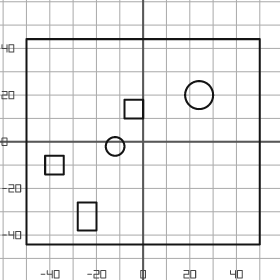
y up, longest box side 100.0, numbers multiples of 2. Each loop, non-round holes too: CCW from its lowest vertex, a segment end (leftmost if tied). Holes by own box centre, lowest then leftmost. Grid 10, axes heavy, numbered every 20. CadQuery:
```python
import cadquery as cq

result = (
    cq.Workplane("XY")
    .moveTo(-50.0, -44.0)
    .lineTo(50.0, -44.0)
    .lineTo(50.0, 44.0)
    .lineTo(-50.0, 44.0)
    .close()
    .moveTo(-28.0, -38.0)
    .lineTo(-20.0, -38.0)
    .lineTo(-20.0, -26.0)
    .lineTo(-28.0, -26.0)
    .close()
    .moveTo(-42.0, -14.0)
    .lineTo(-34.0, -14.0)
    .lineTo(-34.0, -6.0)
    .lineTo(-42.0, -6.0)
    .close()
    .moveTo(-12.0, -2.0)
    .circle(4.0)
    .moveTo(-8.0, 10.0)
    .lineTo(0.0, 10.0)
    .lineTo(0.0, 18.0)
    .lineTo(-8.0, 18.0)
    .close()
    .moveTo(24.0, 20.0)
    .circle(6.0)
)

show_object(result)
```